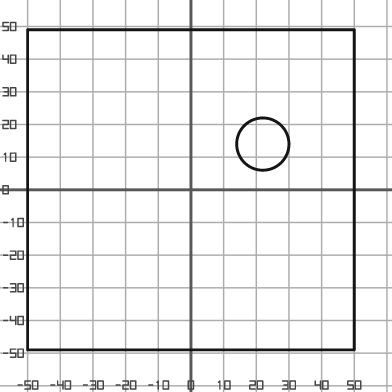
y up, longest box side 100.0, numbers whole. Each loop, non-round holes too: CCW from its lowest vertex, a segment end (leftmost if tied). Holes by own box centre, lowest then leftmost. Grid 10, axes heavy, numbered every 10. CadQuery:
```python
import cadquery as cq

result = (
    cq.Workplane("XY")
    .moveTo(-50.0, -49.0)
    .lineTo(50.0, -49.0)
    .lineTo(50.0, 49.0)
    .lineTo(-50.0, 49.0)
    .close()
    .moveTo(22.0, 14.0)
    .circle(8.0)
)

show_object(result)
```